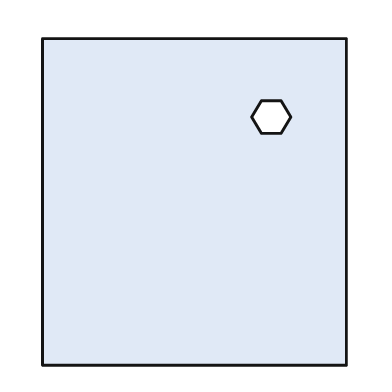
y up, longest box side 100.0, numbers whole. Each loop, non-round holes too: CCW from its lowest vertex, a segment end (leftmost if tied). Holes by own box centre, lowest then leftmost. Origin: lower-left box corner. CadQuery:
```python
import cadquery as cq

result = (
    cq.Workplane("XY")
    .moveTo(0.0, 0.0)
    .lineTo(93.0, 0.0)
    .lineTo(93.0, 100.0)
    .lineTo(0.0, 100.0)
    .close()
    .moveTo(67.0, 71.0)
    .lineTo(73.0, 71.0)
    .lineTo(76.0, 76.0)
    .lineTo(73.0, 81.0)
    .lineTo(67.0, 81.0)
    .lineTo(64.0, 76.0)
    .close()
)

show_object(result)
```